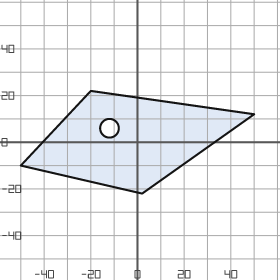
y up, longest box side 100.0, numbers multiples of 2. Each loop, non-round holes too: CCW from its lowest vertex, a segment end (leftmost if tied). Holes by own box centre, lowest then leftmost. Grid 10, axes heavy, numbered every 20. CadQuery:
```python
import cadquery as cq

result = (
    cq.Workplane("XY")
    .moveTo(2.0, -22.0)
    .lineTo(50.0, 12.0)
    .lineTo(-20.0, 22.0)
    .lineTo(-50.0, -10.0)
    .close()
    .moveTo(-12.0, 6.0)
    .circle(4.0)
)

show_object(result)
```